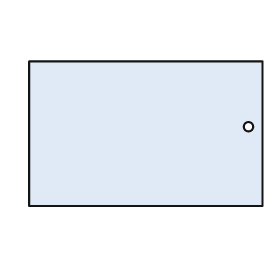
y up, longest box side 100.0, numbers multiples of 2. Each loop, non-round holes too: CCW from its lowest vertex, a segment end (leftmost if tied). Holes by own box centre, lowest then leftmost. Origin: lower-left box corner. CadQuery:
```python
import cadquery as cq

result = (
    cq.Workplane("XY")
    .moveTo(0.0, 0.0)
    .lineTo(100.0, 0.0)
    .lineTo(100.0, 62.0)
    .lineTo(0.0, 62.0)
    .close()
    .moveTo(94.0, 34.0)
    .circle(2.0)
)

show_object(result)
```